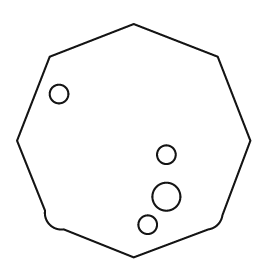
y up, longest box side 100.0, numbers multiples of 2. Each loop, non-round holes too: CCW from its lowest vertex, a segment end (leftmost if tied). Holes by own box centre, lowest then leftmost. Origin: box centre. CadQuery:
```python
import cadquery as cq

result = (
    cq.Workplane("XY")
    .moveTo(0.0, -50.0)
    .lineTo(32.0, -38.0)
    .threePointArc((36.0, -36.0), (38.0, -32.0))
    .lineTo(50.0, 0.0)
    .lineTo(36.0, 36.0)
    .lineTo(0.0, 50.0)
    .lineTo(-36.0, 36.0)
    .lineTo(-50.0, 0.0)
    .lineTo(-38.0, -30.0)
    .threePointArc((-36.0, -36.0), (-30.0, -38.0))
    .close()
    .moveTo(6.0, -36.0)
    .circle(4.0)
    .moveTo(14.0, -24.0)
    .circle(6.0)
    .moveTo(14.0, -6.0)
    .circle(4.0)
    .moveTo(-32.0, 20.0)
    .circle(4.0)
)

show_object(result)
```